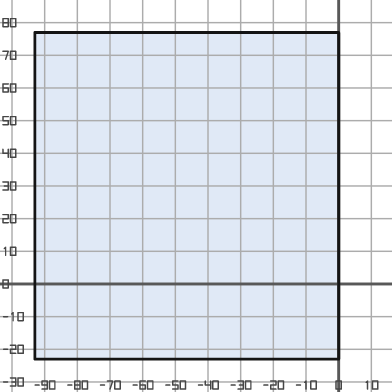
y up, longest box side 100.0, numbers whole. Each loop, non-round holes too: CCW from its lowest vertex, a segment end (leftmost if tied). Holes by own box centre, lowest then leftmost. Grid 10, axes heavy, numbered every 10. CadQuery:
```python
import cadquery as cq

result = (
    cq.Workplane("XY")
    .moveTo(-93.0, -23.0)
    .lineTo(0.0, -23.0)
    .lineTo(0.0, 77.0)
    .lineTo(-93.0, 77.0)
    .close()
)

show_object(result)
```